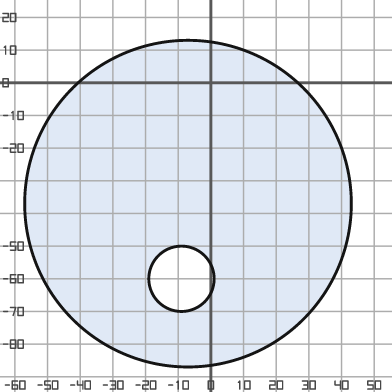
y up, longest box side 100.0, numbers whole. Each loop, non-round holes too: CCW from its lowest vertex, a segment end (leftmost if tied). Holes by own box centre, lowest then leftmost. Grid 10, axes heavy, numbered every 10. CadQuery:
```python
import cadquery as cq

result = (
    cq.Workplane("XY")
    .moveTo(-7.0, -37.0)
    .circle(50.0)
    .moveTo(-9.0, -60.0)
    .circle(10.0)
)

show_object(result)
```